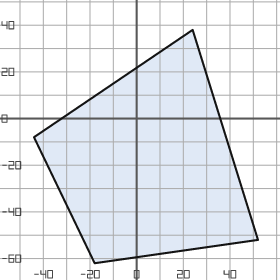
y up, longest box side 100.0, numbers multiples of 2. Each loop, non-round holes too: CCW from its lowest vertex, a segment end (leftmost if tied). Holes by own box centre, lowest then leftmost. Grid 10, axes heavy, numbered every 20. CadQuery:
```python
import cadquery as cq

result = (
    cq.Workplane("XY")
    .moveTo(-18.0, -62.0)
    .lineTo(52.0, -52.0)
    .lineTo(24.0, 38.0)
    .lineTo(-44.0, -8.0)
    .close()
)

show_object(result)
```